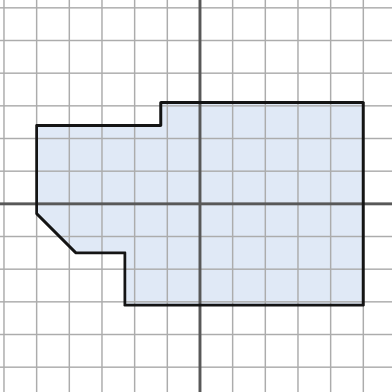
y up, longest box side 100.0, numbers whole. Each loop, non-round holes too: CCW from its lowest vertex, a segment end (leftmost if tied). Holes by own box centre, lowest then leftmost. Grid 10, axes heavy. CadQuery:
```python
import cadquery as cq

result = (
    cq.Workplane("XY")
    .moveTo(-23.0, -31.0)
    .lineTo(50.0, -31.0)
    .lineTo(50.0, 31.0)
    .lineTo(-12.0, 31.0)
    .lineTo(-12.0, 24.0)
    .lineTo(-50.0, 24.0)
    .lineTo(-50.0, -3.0)
    .lineTo(-38.0, -15.0)
    .lineTo(-23.0, -15.0)
    .close()
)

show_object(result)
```